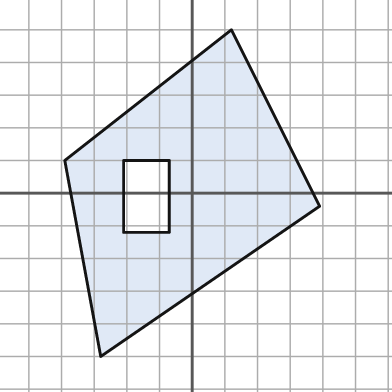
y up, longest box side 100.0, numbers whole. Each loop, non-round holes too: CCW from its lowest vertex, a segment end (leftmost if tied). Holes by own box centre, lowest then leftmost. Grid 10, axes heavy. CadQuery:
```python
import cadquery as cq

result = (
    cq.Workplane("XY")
    .moveTo(-28.0, -50.0)
    .lineTo(39.0, -4.0)
    .lineTo(12.0, 50.0)
    .lineTo(-39.0, 10.0)
    .close()
    .moveTo(-21.0, -12.0)
    .lineTo(-7.0, -12.0)
    .lineTo(-7.0, 10.0)
    .lineTo(-21.0, 10.0)
    .close()
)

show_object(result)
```